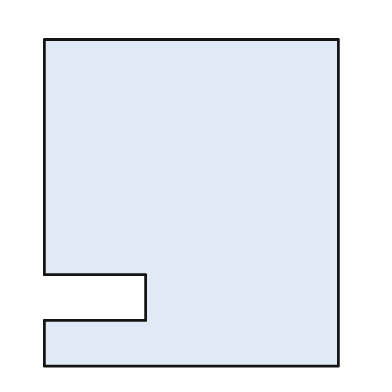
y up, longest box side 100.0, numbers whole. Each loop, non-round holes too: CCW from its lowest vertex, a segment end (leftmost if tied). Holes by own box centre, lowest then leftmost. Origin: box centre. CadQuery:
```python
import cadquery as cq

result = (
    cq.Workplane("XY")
    .moveTo(-45.0, -50.0)
    .lineTo(45.0, -50.0)
    .lineTo(45.0, 50.0)
    .lineTo(-45.0, 50.0)
    .lineTo(-45.0, -22.0)
    .lineTo(-14.0, -22.0)
    .lineTo(-14.0, -36.0)
    .lineTo(-45.0, -36.0)
    .close()
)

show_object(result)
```